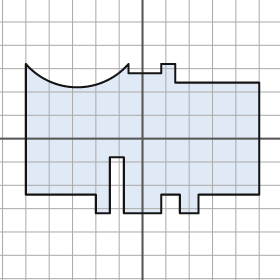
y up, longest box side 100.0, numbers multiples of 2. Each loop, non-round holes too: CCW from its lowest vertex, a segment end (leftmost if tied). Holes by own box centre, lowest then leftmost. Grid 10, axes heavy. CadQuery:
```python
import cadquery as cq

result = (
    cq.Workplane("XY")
    .moveTo(-20.0, -32.0)
    .lineTo(-14.0, -32.0)
    .lineTo(-14.0, -8.0)
    .lineTo(-8.0, -8.0)
    .lineTo(-8.0, -32.0)
    .lineTo(8.0, -32.0)
    .lineTo(8.0, -24.0)
    .lineTo(16.0, -24.0)
    .lineTo(16.0, -32.0)
    .lineTo(24.0, -32.0)
    .lineTo(24.0, -24.0)
    .lineTo(50.0, -24.0)
    .lineTo(50.0, 24.0)
    .lineTo(14.0, 24.0)
    .lineTo(14.0, 32.0)
    .lineTo(8.0, 32.0)
    .lineTo(8.0, 28.0)
    .lineTo(-6.0, 28.0)
    .lineTo(-6.0, 32.0)
    .threePointArc((-28.0, 22.0), (-50.0, 32.0))
    .lineTo(-50.0, -24.0)
    .lineTo(-20.0, -24.0)
    .close()
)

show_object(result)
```